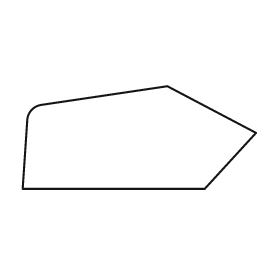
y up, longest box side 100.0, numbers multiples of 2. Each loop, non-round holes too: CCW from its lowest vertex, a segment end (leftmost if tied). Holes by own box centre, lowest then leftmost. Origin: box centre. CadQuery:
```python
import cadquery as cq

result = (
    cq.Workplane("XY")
    .moveTo(-50.0, -22.0)
    .lineTo(28.0, -22.0)
    .lineTo(50.0, 2.0)
    .lineTo(12.0, 22.0)
    .lineTo(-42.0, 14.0)
    .threePointArc((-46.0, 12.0), (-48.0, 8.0))
    .close()
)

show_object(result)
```